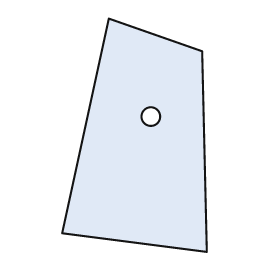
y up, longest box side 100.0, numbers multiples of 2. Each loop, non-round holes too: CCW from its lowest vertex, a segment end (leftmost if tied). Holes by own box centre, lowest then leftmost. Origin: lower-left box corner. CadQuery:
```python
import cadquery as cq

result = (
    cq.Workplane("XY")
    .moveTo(62.0, 0.0)
    .lineTo(60.0, 86.0)
    .lineTo(20.0, 100.0)
    .lineTo(0.0, 8.0)
    .close()
    .moveTo(38.0, 58.0)
    .circle(4.0)
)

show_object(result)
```